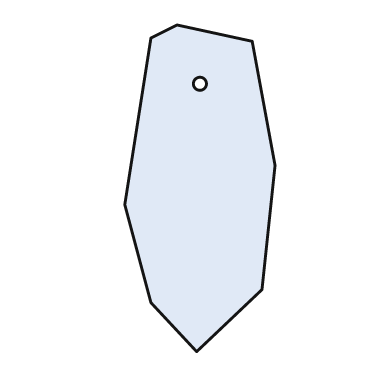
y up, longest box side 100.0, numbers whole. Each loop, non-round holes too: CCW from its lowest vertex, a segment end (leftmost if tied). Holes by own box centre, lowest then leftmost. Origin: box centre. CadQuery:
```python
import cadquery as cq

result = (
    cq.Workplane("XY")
    .moveTo(-1.0, -50.0)
    .lineTo(19.0, -31.0)
    .lineTo(23.0, 7.0)
    .lineTo(16.0, 45.0)
    .lineTo(-7.0, 50.0)
    .lineTo(-15.0, 46.0)
    .lineTo(-23.0, -5.0)
    .lineTo(-15.0, -35.0)
    .close()
    .moveTo(0.0, 32.0)
    .circle(2.0)
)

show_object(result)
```